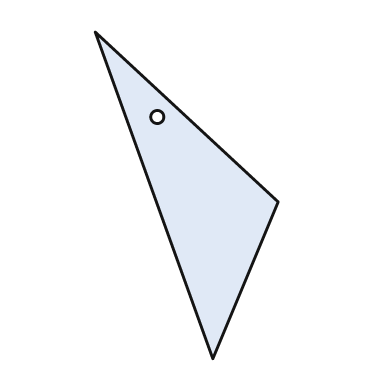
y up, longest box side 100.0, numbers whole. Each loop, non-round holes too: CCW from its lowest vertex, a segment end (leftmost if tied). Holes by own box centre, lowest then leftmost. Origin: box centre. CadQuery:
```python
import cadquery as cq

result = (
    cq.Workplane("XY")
    .moveTo(8.0, -50.0)
    .lineTo(28.0, -2.0)
    .lineTo(-28.0, 50.0)
    .close()
    .moveTo(-9.0, 24.0)
    .circle(2.0)
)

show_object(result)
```